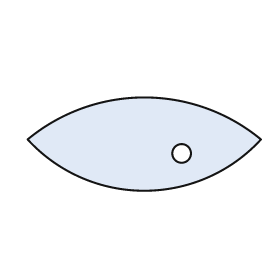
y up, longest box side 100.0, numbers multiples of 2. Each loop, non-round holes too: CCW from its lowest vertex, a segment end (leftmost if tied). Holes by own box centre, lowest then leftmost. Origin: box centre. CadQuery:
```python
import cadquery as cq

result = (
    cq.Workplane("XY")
    .moveTo(-50.0, 2.0)
    .threePointArc((0.0, -20.0), (50.0, 2.0))
    .threePointArc((0.0, 20.0), (-50.0, 2.0))
    .close()
    .moveTo(16.0, -4.0)
    .circle(4.0)
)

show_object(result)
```